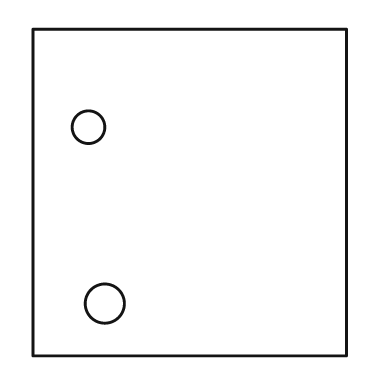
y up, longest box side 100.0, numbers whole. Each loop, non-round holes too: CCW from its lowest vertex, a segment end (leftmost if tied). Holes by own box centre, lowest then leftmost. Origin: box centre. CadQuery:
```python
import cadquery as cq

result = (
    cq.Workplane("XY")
    .moveTo(-48.0, -50.0)
    .lineTo(48.0, -50.0)
    .lineTo(48.0, 50.0)
    .lineTo(-48.0, 50.0)
    .close()
    .moveTo(-26.0, -34.0)
    .circle(6.0)
    .moveTo(-31.0, 20.0)
    .circle(5.0)
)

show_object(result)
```